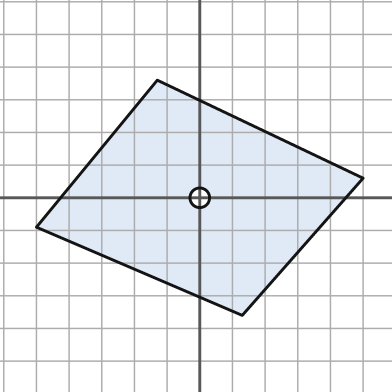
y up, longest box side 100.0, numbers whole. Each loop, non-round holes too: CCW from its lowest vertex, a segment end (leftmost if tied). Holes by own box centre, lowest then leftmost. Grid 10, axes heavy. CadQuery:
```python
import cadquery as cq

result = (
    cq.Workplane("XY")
    .moveTo(13.0, -36.0)
    .lineTo(50.0, 6.0)
    .lineTo(-13.0, 36.0)
    .lineTo(-50.0, -9.0)
    .close()
    .moveTo(0.0, 0.0)
    .circle(3.0)
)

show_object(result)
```